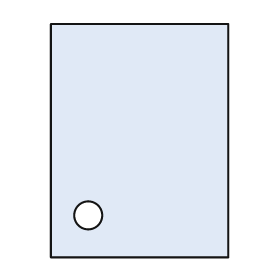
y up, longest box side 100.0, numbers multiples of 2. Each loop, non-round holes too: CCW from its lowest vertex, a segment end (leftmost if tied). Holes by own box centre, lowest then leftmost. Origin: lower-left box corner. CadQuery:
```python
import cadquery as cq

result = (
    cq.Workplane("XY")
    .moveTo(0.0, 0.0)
    .lineTo(76.0, 0.0)
    .lineTo(76.0, 100.0)
    .lineTo(0.0, 100.0)
    .close()
    .moveTo(16.0, 18.0)
    .circle(6.0)
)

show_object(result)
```